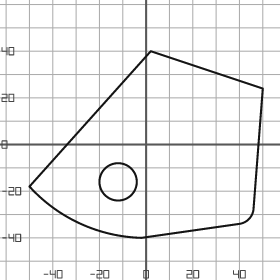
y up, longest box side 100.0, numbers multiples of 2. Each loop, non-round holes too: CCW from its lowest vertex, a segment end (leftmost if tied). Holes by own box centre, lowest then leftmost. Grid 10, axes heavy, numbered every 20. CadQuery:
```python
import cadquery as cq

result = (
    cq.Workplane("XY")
    .moveTo(-2.0, -40.0)
    .lineTo(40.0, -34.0)
    .threePointArc((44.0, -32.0), (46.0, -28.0))
    .lineTo(50.0, 24.0)
    .lineTo(2.0, 40.0)
    .lineTo(-50.0, -18.0)
    .threePointArc((-28.0, -34.0), (-2.0, -40.0))
    .close()
    .moveTo(-12.0, -16.0)
    .circle(8.0)
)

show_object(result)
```